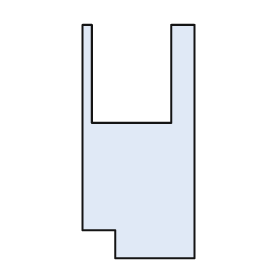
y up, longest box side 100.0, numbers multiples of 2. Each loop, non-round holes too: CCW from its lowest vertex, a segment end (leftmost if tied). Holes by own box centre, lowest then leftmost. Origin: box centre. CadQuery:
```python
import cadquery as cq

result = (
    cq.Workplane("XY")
    .moveTo(-10.0, -50.0)
    .lineTo(24.0, -50.0)
    .lineTo(24.0, 50.0)
    .lineTo(14.0, 50.0)
    .lineTo(14.0, 8.0)
    .lineTo(-20.0, 8.0)
    .lineTo(-20.0, 50.0)
    .lineTo(-24.0, 50.0)
    .lineTo(-24.0, -38.0)
    .lineTo(-10.0, -38.0)
    .close()
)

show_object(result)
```